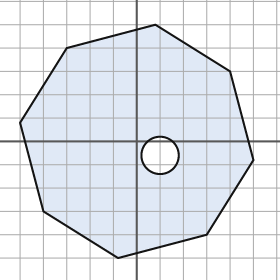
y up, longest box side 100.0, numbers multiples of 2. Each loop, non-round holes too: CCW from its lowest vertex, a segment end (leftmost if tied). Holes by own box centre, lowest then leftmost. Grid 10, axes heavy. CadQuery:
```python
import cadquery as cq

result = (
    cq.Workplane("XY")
    .moveTo(-8.0, -50.0)
    .lineTo(30.0, -40.0)
    .lineTo(50.0, -8.0)
    .lineTo(40.0, 30.0)
    .lineTo(8.0, 50.0)
    .lineTo(-30.0, 40.0)
    .lineTo(-50.0, 8.0)
    .lineTo(-40.0, -30.0)
    .close()
    .moveTo(10.0, -6.0)
    .circle(8.0)
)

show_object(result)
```